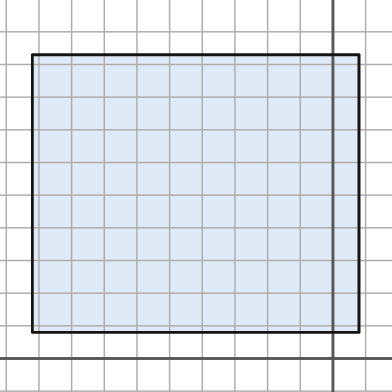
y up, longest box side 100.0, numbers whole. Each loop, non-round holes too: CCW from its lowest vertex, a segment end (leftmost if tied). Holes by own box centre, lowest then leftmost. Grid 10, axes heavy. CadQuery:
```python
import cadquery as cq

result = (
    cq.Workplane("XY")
    .moveTo(-92.0, 8.0)
    .lineTo(8.0, 8.0)
    .lineTo(8.0, 93.0)
    .lineTo(-92.0, 93.0)
    .close()
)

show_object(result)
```